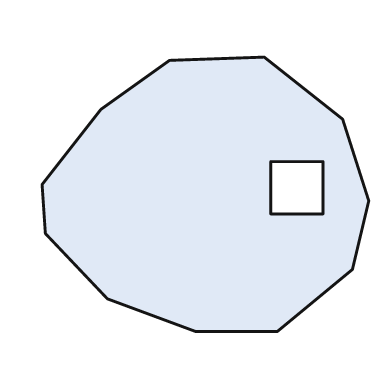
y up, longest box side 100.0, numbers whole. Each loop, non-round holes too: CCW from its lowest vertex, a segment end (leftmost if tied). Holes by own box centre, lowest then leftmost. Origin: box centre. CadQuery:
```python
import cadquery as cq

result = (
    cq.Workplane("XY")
    .moveTo(-3.0, -42.0)
    .lineTo(22.0, -42.0)
    .lineTo(45.0, -23.0)
    .lineTo(50.0, -2.0)
    .lineTo(42.0, 23.0)
    .lineTo(18.0, 42.0)
    .lineTo(-11.0, 41.0)
    .lineTo(-32.0, 26.0)
    .lineTo(-50.0, 3.0)
    .lineTo(-49.0, -12.0)
    .lineTo(-30.0, -32.0)
    .close()
    .moveTo(20.0, -6.0)
    .lineTo(36.0, -6.0)
    .lineTo(36.0, 10.0)
    .lineTo(20.0, 10.0)
    .close()
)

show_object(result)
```